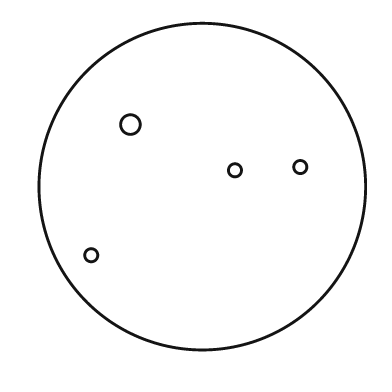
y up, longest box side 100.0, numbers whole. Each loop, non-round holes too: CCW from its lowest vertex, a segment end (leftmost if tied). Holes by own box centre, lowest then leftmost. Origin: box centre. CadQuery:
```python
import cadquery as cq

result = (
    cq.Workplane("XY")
    .moveTo(0.0, 0.0)
    .circle(50.0)
    .moveTo(-34.0, -21.0)
    .circle(2.0)
    .moveTo(10.0, 5.0)
    .circle(2.0)
    .moveTo(30.0, 6.0)
    .circle(2.0)
    .moveTo(-22.0, 19.0)
    .circle(3.0)
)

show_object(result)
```